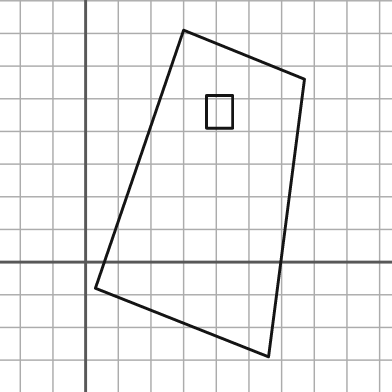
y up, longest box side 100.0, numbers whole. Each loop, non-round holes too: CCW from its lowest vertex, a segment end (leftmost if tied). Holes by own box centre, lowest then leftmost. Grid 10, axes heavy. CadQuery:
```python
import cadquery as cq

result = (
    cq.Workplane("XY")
    .moveTo(56.0, -29.0)
    .lineTo(67.0, 56.0)
    .lineTo(30.0, 71.0)
    .lineTo(3.0, -8.0)
    .close()
    .moveTo(37.0, 41.0)
    .lineTo(45.0, 41.0)
    .lineTo(45.0, 51.0)
    .lineTo(37.0, 51.0)
    .close()
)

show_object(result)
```